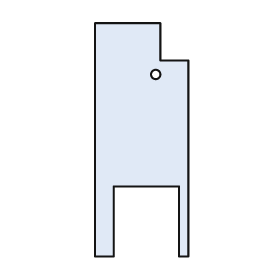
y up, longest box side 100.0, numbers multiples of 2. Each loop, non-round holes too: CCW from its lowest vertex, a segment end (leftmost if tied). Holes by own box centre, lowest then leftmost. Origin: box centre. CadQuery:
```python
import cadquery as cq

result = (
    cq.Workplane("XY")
    .moveTo(-20.0, -50.0)
    .lineTo(-12.0, -50.0)
    .lineTo(-12.0, -20.0)
    .lineTo(16.0, -20.0)
    .lineTo(16.0, -50.0)
    .lineTo(20.0, -50.0)
    .lineTo(20.0, 34.0)
    .lineTo(8.0, 34.0)
    .lineTo(8.0, 50.0)
    .lineTo(-20.0, 50.0)
    .close()
    .moveTo(6.0, 28.0)
    .circle(2.0)
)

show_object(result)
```